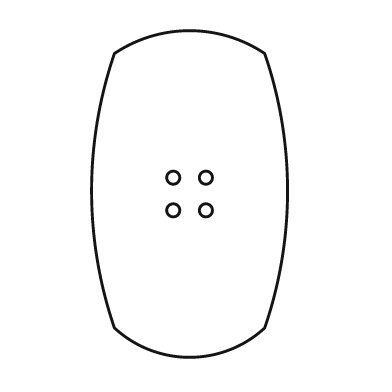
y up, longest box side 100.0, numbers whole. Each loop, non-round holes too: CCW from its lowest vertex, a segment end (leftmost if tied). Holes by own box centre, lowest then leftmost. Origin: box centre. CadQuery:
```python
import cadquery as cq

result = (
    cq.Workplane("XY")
    .moveTo(-23.0, -41.0)
    .threePointArc((0.0, -50.0), (23.0, -41.0))
    .threePointArc((30.0, 1.0), (23.0, 43.0))
    .threePointArc((0.0, 50.0), (-23.0, 43.0))
    .threePointArc((-30.0, 1.0), (-23.0, -41.0))
    .close()
    .moveTo(-5.0, -5.0)
    .circle(2.0)
    .moveTo(5.0, -5.0)
    .circle(2.0)
    .moveTo(-5.0, 5.0)
    .circle(2.0)
    .moveTo(5.0, 5.0)
    .circle(2.0)
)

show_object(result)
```